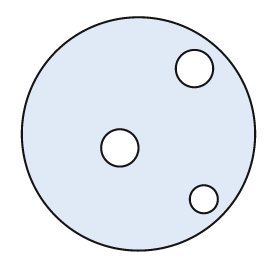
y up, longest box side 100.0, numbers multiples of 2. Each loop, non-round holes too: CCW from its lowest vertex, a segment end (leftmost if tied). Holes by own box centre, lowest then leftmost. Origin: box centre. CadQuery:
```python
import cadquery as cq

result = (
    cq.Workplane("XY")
    .moveTo(0.0, 0.0)
    .circle(50.0)
    .moveTo(28.0, -28.0)
    .circle(6.0)
    .moveTo(-8.0, -6.0)
    .circle(8.0)
    .moveTo(24.0, 28.0)
    .circle(8.0)
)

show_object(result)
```